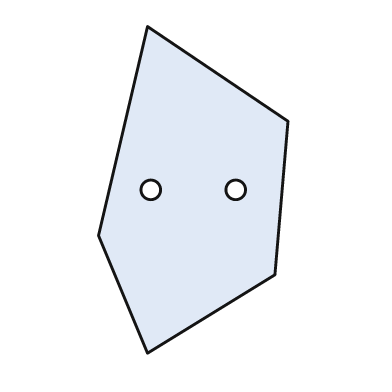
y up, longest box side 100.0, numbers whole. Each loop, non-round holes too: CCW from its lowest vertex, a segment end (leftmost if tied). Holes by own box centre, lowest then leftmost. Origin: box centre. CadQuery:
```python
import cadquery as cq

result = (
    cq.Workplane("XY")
    .moveTo(-14.0, -50.0)
    .lineTo(25.0, -26.0)
    .lineTo(29.0, 21.0)
    .lineTo(-14.0, 50.0)
    .lineTo(-29.0, -14.0)
    .close()
    .moveTo(-13.0, 0.0)
    .circle(3.0)
    .moveTo(13.0, 0.0)
    .circle(3.0)
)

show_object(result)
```